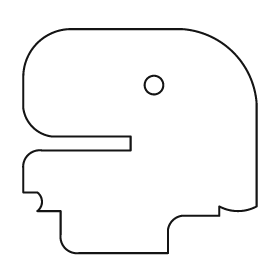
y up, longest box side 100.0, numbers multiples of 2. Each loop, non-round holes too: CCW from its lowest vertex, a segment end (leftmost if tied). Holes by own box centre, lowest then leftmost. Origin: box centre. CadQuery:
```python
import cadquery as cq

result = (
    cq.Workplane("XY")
    .moveTo(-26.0, -48.0)
    .lineTo(12.0, -48.0)
    .lineTo(12.0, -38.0)
    .threePointArc((14.0, -34.0), (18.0, -32.0))
    .lineTo(34.0, -32.0)
    .lineTo(34.0, -28.0)
    .threePointArc((42.0, -30.0), (50.0, -28.0))
    .lineTo(50.0, 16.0)
    .threePointArc((40.0, 38.0), (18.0, 48.0))
    .lineTo(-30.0, 48.0)
    .threePointArc((-44.0, 42.0), (-50.0, 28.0))
    .lineTo(-50.0, 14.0)
    .threePointArc((-46.0, 6.0), (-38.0, 2.0))
    .lineTo(-4.0, 2.0)
    .lineTo(-4.0, -4.0)
    .lineTo(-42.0, -4.0)
    .threePointArc((-48.0, -6.0), (-50.0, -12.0))
    .lineTo(-50.0, -22.0)
    .lineTo(-44.0, -22.0)
    .threePointArc((-42.0, -26.0), (-44.0, -30.0))
    .lineTo(-34.0, -30.0)
    .lineTo(-34.0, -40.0)
    .threePointArc((-32.0, -46.0), (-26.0, -48.0))
    .close()
    .moveTo(6.0, 24.0)
    .circle(4.0)
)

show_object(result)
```